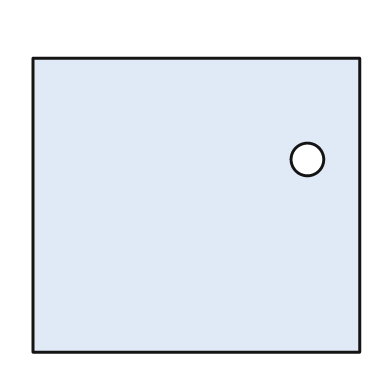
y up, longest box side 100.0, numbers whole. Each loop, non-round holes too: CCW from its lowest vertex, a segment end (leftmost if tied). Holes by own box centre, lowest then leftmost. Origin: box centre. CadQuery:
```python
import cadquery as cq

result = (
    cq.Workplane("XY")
    .moveTo(-50.0, -45.0)
    .lineTo(50.0, -45.0)
    .lineTo(50.0, 45.0)
    .lineTo(-50.0, 45.0)
    .close()
    .moveTo(34.0, 14.0)
    .circle(5.0)
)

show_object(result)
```